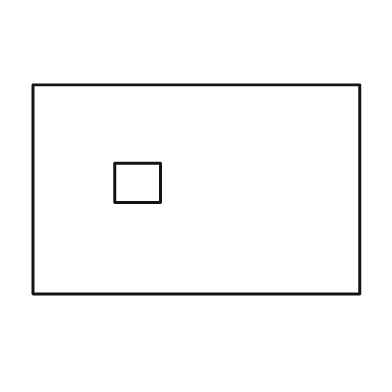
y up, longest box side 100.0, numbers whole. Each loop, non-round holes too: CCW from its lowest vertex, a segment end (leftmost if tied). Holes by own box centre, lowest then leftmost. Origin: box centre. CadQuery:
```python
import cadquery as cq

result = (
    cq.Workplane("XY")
    .moveTo(-50.0, -32.0)
    .lineTo(50.0, -32.0)
    .lineTo(50.0, 32.0)
    .lineTo(-50.0, 32.0)
    .close()
    .moveTo(-25.0, -4.0)
    .lineTo(-11.0, -4.0)
    .lineTo(-11.0, 8.0)
    .lineTo(-25.0, 8.0)
    .close()
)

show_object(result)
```